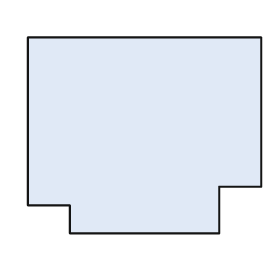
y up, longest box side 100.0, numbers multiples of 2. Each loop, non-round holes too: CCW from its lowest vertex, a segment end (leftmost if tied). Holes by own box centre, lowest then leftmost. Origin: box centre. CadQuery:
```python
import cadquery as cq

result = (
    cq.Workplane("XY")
    .moveTo(-32.0, -42.0)
    .lineTo(32.0, -42.0)
    .lineTo(32.0, -22.0)
    .lineTo(50.0, -22.0)
    .lineTo(50.0, 42.0)
    .lineTo(-50.0, 42.0)
    .lineTo(-50.0, -30.0)
    .lineTo(-32.0, -30.0)
    .close()
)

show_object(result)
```